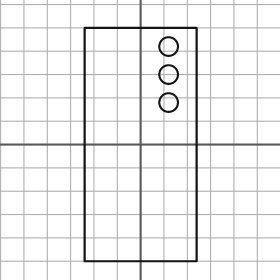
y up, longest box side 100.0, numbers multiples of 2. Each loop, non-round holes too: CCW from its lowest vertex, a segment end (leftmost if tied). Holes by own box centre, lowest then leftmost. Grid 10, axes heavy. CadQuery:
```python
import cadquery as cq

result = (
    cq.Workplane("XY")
    .moveTo(-24.0, -50.0)
    .lineTo(24.0, -50.0)
    .lineTo(24.0, 50.0)
    .lineTo(-24.0, 50.0)
    .close()
    .moveTo(12.0, 18.0)
    .circle(4.0)
    .moveTo(12.0, 30.0)
    .circle(4.0)
    .moveTo(12.0, 42.0)
    .circle(4.0)
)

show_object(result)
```